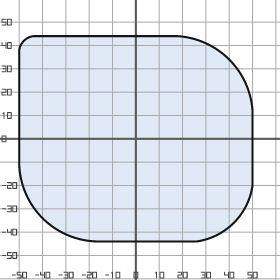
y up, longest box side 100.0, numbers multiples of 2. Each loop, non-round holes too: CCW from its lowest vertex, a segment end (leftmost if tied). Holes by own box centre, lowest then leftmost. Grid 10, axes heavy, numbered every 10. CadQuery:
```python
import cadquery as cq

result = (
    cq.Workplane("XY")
    .moveTo(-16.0, -44.0)
    .lineTo(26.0, -44.0)
    .threePointArc((42.0, -36.0), (50.0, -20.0))
    .lineTo(50.0, 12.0)
    .threePointArc((40.0, 34.0), (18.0, 44.0))
    .lineTo(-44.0, 44.0)
    .threePointArc((-48.0, 42.0), (-50.0, 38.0))
    .lineTo(-50.0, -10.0)
    .threePointArc((-40.0, -34.0), (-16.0, -44.0))
    .close()
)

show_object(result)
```